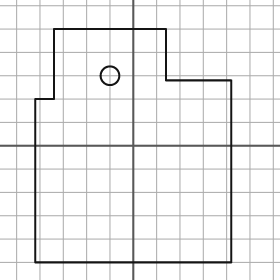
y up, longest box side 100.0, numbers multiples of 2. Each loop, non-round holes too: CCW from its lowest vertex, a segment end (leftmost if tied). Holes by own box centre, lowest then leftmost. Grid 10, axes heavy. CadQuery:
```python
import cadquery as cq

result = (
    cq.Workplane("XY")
    .moveTo(-42.0, -50.0)
    .lineTo(42.0, -50.0)
    .lineTo(42.0, 28.0)
    .lineTo(14.0, 28.0)
    .lineTo(14.0, 50.0)
    .lineTo(-34.0, 50.0)
    .lineTo(-34.0, 20.0)
    .lineTo(-42.0, 20.0)
    .close()
    .moveTo(-10.0, 30.0)
    .circle(4.0)
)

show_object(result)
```